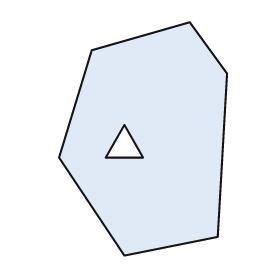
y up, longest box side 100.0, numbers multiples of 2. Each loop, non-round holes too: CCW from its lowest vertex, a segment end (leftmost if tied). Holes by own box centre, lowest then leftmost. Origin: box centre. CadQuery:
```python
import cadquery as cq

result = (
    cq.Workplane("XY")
    .moveTo(-8.0, -50.0)
    .lineTo(32.0, -42.0)
    .lineTo(36.0, 28.0)
    .lineTo(20.0, 50.0)
    .lineTo(-22.0, 38.0)
    .lineTo(-36.0, -8.0)
    .close()
    .moveTo(-16.0, -8.0)
    .lineTo(0.0, -8.0)
    .lineTo(-8.0, 6.0)
    .close()
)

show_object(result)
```